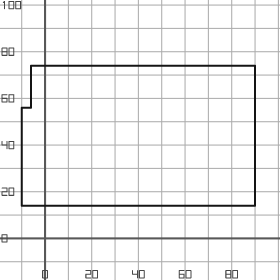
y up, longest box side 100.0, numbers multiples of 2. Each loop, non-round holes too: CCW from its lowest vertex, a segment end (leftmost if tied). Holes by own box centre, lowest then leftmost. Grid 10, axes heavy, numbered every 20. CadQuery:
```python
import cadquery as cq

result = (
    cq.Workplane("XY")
    .moveTo(-10.0, 14.0)
    .lineTo(90.0, 14.0)
    .lineTo(90.0, 74.0)
    .lineTo(-6.0, 74.0)
    .lineTo(-6.0, 56.0)
    .lineTo(-10.0, 56.0)
    .close()
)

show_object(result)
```